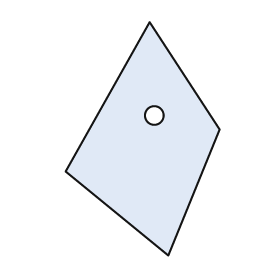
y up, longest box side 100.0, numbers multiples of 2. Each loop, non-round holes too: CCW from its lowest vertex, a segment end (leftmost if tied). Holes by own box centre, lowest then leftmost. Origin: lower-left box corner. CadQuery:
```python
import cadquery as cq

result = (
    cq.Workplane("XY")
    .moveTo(44.0, 0.0)
    .lineTo(66.0, 54.0)
    .lineTo(36.0, 100.0)
    .lineTo(0.0, 36.0)
    .close()
    .moveTo(38.0, 60.0)
    .circle(4.0)
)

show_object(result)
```